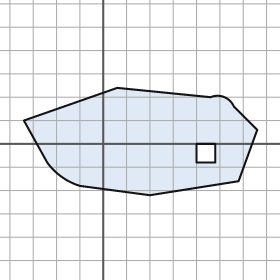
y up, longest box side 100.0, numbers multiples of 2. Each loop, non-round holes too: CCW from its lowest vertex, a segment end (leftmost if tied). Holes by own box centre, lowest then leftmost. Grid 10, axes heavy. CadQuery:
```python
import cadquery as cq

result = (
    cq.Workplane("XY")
    .moveTo(20.0, -22.0)
    .lineTo(58.0, -16.0)
    .lineTo(66.0, 6.0)
    .lineTo(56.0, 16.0)
    .threePointArc((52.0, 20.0), (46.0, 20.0))
    .lineTo(6.0, 24.0)
    .lineTo(-34.0, 10.0)
    .lineTo(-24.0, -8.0)
    .threePointArc((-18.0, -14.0), (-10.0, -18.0))
    .close()
    .moveTo(40.0, -8.0)
    .lineTo(48.0, -8.0)
    .lineTo(48.0, 0.0)
    .lineTo(40.0, 0.0)
    .close()
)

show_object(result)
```